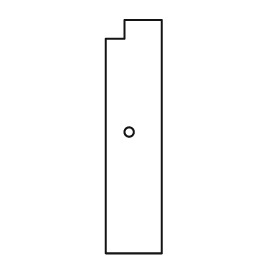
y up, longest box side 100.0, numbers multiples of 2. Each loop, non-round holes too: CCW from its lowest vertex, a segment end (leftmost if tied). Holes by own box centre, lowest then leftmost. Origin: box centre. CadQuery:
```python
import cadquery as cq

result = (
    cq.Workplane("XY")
    .moveTo(-12.0, -50.0)
    .lineTo(12.0, -50.0)
    .lineTo(12.0, 50.0)
    .lineTo(-4.0, 50.0)
    .lineTo(-4.0, 42.0)
    .lineTo(-12.0, 42.0)
    .close()
    .moveTo(-2.0, 2.0)
    .circle(2.0)
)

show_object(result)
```